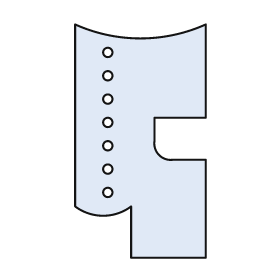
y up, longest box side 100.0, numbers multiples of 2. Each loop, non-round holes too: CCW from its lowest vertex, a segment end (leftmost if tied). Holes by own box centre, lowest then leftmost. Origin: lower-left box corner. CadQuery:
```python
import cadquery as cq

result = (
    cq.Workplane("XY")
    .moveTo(24.0, 0.0)
    .lineTo(56.0, 0.0)
    .lineTo(56.0, 42.0)
    .lineTo(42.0, 42.0)
    .threePointArc((36.0, 44.0), (34.0, 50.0))
    .lineTo(34.0, 60.0)
    .lineTo(56.0, 60.0)
    .lineTo(56.0, 100.0)
    .threePointArc((28.0, 94.0), (0.0, 100.0))
    .lineTo(0.0, 22.0)
    .threePointArc((12.0, 18.0), (24.0, 22.0))
    .close()
    .moveTo(14.0, 28.0)
    .circle(2.0)
    .moveTo(14.0, 38.0)
    .circle(2.0)
    .moveTo(14.0, 48.0)
    .circle(2.0)
    .moveTo(14.0, 58.0)
    .circle(2.0)
    .moveTo(14.0, 68.0)
    .circle(2.0)
    .moveTo(14.0, 78.0)
    .circle(2.0)
    .moveTo(14.0, 88.0)
    .circle(2.0)
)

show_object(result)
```